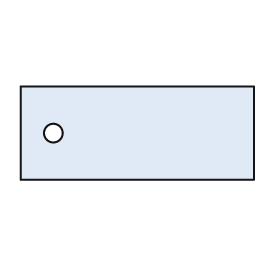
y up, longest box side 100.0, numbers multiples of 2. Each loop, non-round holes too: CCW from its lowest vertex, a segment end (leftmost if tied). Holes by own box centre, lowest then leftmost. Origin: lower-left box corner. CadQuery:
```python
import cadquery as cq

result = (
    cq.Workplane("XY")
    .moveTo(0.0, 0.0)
    .lineTo(100.0, 0.0)
    .lineTo(100.0, 40.0)
    .lineTo(0.0, 40.0)
    .close()
    .moveTo(14.0, 20.0)
    .circle(4.0)
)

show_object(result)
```